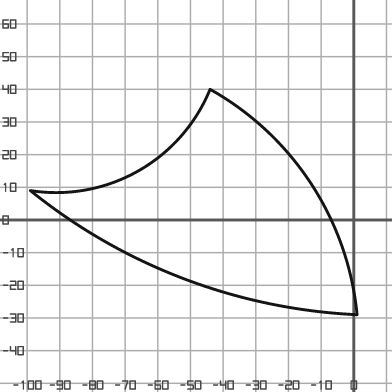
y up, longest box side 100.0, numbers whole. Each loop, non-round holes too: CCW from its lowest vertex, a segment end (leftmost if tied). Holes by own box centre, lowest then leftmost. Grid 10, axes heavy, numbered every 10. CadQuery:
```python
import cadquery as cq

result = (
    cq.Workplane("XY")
    .moveTo(1.0, -29.0)
    .threePointArc((-13.0, 11.0), (-44.0, 40.0))
    .threePointArc((-66.0, 15.0), (-99.0, 9.0))
    .threePointArc((-52.0, -18.0), (1.0, -29.0))
    .close()
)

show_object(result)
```